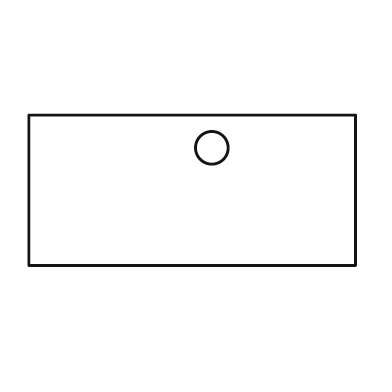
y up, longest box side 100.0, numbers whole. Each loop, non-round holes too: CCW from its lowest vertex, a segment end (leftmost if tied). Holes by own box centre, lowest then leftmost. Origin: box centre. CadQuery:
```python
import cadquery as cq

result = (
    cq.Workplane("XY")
    .moveTo(-50.0, -23.0)
    .lineTo(50.0, -23.0)
    .lineTo(50.0, 23.0)
    .lineTo(-50.0, 23.0)
    .close()
    .moveTo(6.0, 13.0)
    .circle(5.0)
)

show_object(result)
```